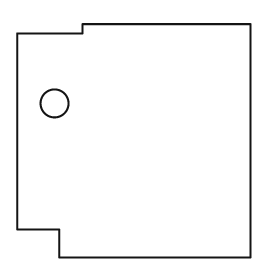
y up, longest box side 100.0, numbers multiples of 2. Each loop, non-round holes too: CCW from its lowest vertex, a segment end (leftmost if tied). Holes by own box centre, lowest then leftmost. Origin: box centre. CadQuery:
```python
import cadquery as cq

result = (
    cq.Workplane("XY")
    .moveTo(-32.0, -50.0)
    .lineTo(50.0, -50.0)
    .lineTo(50.0, 50.0)
    .lineTo(-22.0, 50.0)
    .lineTo(-22.0, 46.0)
    .lineTo(-50.0, 46.0)
    .lineTo(-50.0, -38.0)
    .lineTo(-32.0, -38.0)
    .close()
    .moveTo(-34.0, 16.0)
    .circle(6.0)
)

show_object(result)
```